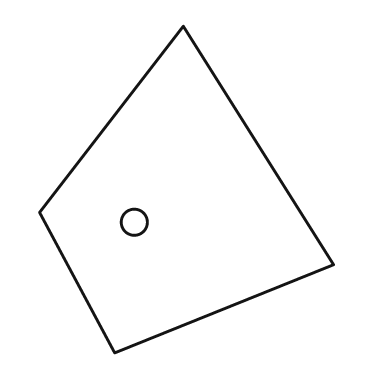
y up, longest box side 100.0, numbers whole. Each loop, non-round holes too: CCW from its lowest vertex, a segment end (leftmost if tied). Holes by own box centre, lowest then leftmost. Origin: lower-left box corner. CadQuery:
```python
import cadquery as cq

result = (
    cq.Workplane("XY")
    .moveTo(23.0, 0.0)
    .lineTo(90.0, 27.0)
    .lineTo(44.0, 100.0)
    .lineTo(0.0, 43.0)
    .close()
    .moveTo(29.0, 40.0)
    .circle(4.0)
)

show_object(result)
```